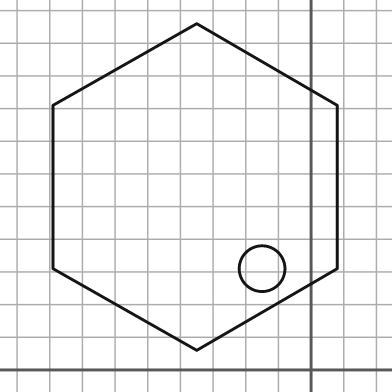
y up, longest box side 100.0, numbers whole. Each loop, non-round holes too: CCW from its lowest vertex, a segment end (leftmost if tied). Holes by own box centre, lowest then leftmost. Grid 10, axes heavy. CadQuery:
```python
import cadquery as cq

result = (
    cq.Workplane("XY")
    .moveTo(-35.0, 6.0)
    .lineTo(8.0, 31.0)
    .lineTo(8.0, 81.0)
    .lineTo(-35.0, 106.0)
    .lineTo(-79.0, 81.0)
    .lineTo(-79.0, 31.0)
    .close()
    .moveTo(-15.0, 31.0)
    .circle(7.0)
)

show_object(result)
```